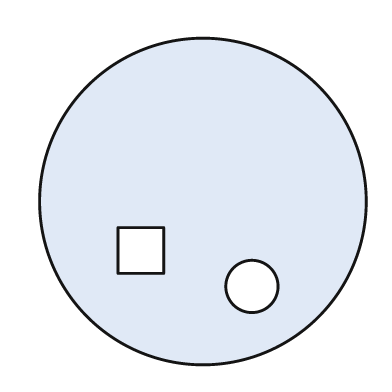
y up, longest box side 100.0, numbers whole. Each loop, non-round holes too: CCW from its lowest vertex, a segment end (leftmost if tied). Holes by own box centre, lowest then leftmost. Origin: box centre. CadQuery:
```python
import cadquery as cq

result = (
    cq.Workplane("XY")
    .moveTo(0.0, 0.0)
    .circle(50.0)
    .moveTo(15.0, -26.0)
    .circle(8.0)
    .moveTo(-26.0, -22.0)
    .lineTo(-12.0, -22.0)
    .lineTo(-12.0, -8.0)
    .lineTo(-26.0, -8.0)
    .close()
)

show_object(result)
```